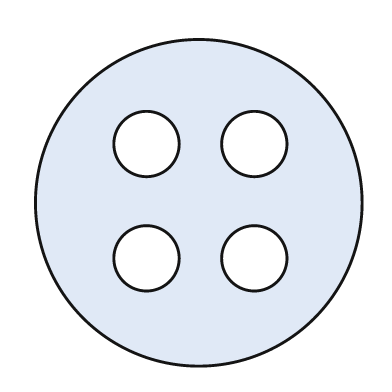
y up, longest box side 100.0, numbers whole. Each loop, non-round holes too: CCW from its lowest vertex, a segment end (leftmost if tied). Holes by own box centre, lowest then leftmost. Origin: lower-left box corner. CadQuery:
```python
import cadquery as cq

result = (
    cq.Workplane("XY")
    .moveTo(50.0, 50.0)
    .circle(50.0)
    .moveTo(34.0, 33.0)
    .circle(10.0)
    .moveTo(67.0, 33.0)
    .circle(10.0)
    .moveTo(34.0, 68.0)
    .circle(10.0)
    .moveTo(67.0, 68.0)
    .circle(10.0)
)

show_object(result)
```